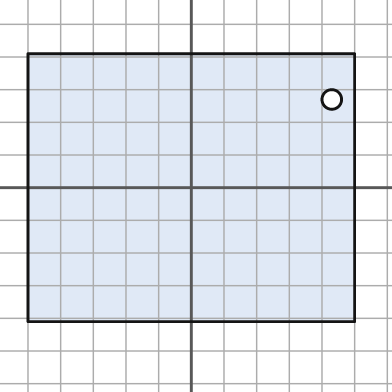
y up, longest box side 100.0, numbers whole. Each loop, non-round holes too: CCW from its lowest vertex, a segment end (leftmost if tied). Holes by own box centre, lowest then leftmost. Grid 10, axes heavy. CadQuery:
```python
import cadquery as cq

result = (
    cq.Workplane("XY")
    .moveTo(-50.0, -41.0)
    .lineTo(50.0, -41.0)
    .lineTo(50.0, 41.0)
    .lineTo(-50.0, 41.0)
    .close()
    .moveTo(43.0, 27.0)
    .circle(3.0)
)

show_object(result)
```